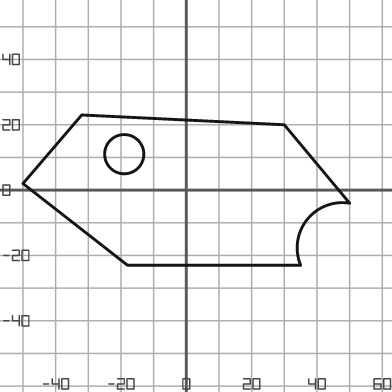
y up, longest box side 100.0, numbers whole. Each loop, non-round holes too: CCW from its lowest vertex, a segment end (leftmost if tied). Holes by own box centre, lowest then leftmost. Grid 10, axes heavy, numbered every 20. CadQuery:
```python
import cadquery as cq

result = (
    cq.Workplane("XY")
    .moveTo(-18.0, -23.0)
    .lineTo(35.0, -23.0)
    .threePointArc((37.0, -9.0), (50.0, -4.0))
    .lineTo(30.0, 20.0)
    .lineTo(-32.0, 23.0)
    .lineTo(-50.0, 2.0)
    .close()
    .moveTo(-19.0, 11.0)
    .circle(6.0)
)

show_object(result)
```